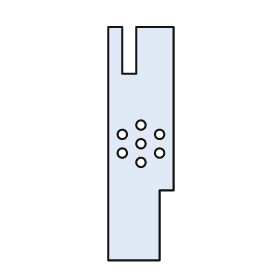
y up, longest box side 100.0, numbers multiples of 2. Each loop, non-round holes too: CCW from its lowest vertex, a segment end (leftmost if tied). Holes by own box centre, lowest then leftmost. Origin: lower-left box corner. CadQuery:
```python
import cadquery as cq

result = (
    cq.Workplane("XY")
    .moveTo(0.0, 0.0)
    .lineTo(22.0, 0.0)
    .lineTo(22.0, 30.0)
    .lineTo(28.0, 30.0)
    .lineTo(28.0, 100.0)
    .lineTo(12.0, 100.0)
    .lineTo(12.0, 80.0)
    .lineTo(6.0, 80.0)
    .lineTo(6.0, 100.0)
    .lineTo(0.0, 100.0)
    .close()
    .moveTo(14.0, 42.0)
    .circle(2.0)
    .moveTo(6.0, 46.0)
    .circle(2.0)
    .moveTo(22.0, 46.0)
    .circle(2.0)
    .moveTo(14.0, 50.0)
    .circle(2.0)
    .moveTo(6.0, 54.0)
    .circle(2.0)
    .moveTo(22.0, 54.0)
    .circle(2.0)
    .moveTo(14.0, 58.0)
    .circle(2.0)
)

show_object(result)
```